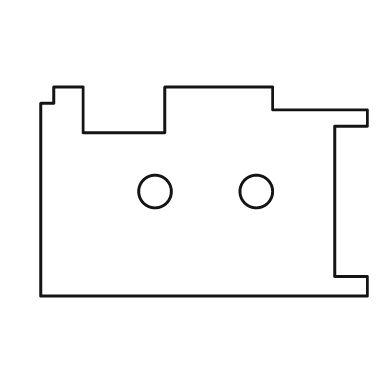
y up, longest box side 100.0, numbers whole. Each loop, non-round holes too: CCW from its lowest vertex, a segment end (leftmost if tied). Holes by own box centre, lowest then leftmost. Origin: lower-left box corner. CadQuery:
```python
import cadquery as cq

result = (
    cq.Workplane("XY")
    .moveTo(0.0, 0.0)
    .lineTo(100.0, 0.0)
    .lineTo(100.0, 6.0)
    .lineTo(90.0, 6.0)
    .lineTo(90.0, 52.0)
    .lineTo(100.0, 52.0)
    .lineTo(100.0, 57.0)
    .lineTo(71.0, 57.0)
    .lineTo(71.0, 64.0)
    .lineTo(38.0, 64.0)
    .lineTo(38.0, 50.0)
    .lineTo(13.0, 50.0)
    .lineTo(13.0, 64.0)
    .lineTo(4.0, 64.0)
    .lineTo(4.0, 59.0)
    .lineTo(0.0, 59.0)
    .close()
    .moveTo(35.0, 32.0)
    .circle(5.0)
    .moveTo(66.0, 32.0)
    .circle(5.0)
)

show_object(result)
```